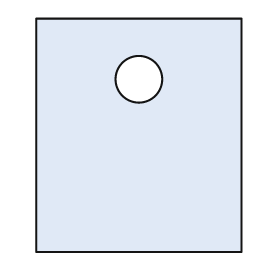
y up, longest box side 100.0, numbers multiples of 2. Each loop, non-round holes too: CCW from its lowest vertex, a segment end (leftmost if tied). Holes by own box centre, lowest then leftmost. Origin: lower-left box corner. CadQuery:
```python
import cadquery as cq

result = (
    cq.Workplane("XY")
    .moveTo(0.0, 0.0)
    .lineTo(88.0, 0.0)
    .lineTo(88.0, 100.0)
    .lineTo(0.0, 100.0)
    .close()
    .moveTo(44.0, 74.0)
    .circle(10.0)
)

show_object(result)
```